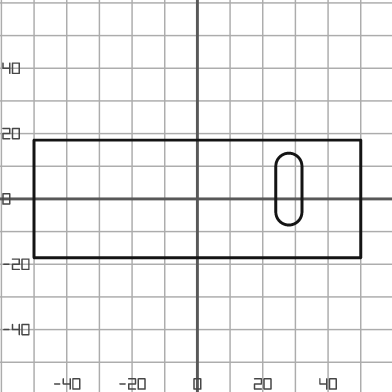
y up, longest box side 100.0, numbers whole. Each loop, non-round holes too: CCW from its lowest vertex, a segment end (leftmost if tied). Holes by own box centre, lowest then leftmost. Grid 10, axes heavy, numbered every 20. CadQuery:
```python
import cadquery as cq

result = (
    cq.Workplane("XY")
    .moveTo(-50.0, -18.0)
    .lineTo(50.0, -18.0)
    .lineTo(50.0, 18.0)
    .lineTo(-50.0, 18.0)
    .close()
    .moveTo(24.0, -4.0)
    .threePointArc((28.0, -8.0), (32.0, -4.0))
    .lineTo(32.0, 10.0)
    .threePointArc((28.0, 14.0), (24.0, 10.0))
    .close()
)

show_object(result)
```